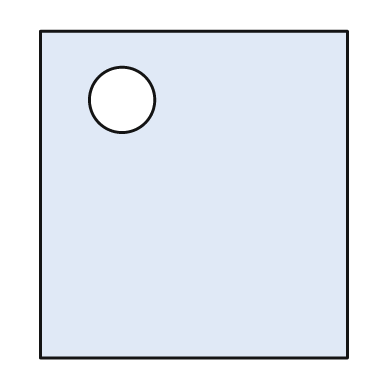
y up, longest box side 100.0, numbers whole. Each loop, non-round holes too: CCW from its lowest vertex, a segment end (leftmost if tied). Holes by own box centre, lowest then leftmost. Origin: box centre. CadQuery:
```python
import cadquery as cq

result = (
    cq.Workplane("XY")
    .moveTo(-47.0, -50.0)
    .lineTo(47.0, -50.0)
    .lineTo(47.0, 50.0)
    .lineTo(-47.0, 50.0)
    .close()
    .moveTo(-22.0, 29.0)
    .circle(10.0)
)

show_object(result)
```